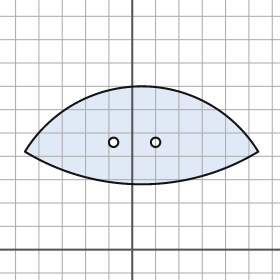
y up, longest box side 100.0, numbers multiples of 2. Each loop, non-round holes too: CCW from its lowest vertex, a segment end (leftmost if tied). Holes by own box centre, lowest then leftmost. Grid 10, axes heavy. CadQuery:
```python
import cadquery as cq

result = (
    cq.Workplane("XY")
    .moveTo(-46.0, 42.0)
    .threePointArc((4.0, 28.0), (54.0, 42.0))
    .threePointArc((4.0, 70.0), (-46.0, 42.0))
    .close()
    .moveTo(-8.0, 46.0)
    .circle(2.0)
    .moveTo(10.0, 46.0)
    .circle(2.0)
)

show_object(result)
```